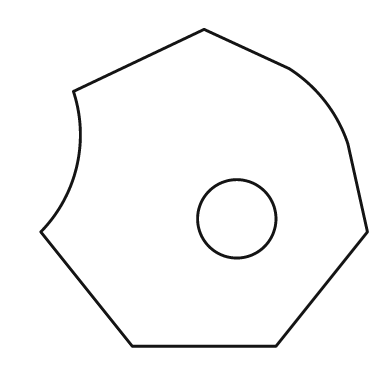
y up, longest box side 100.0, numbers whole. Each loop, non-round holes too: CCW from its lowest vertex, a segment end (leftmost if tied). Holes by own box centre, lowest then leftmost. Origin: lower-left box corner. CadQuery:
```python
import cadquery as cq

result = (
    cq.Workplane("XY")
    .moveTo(28.0, 0.0)
    .lineTo(72.0, 0.0)
    .lineTo(100.0, 35.0)
    .lineTo(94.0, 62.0)
    .threePointArc((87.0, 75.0), (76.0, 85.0))
    .lineTo(50.0, 97.0)
    .lineTo(10.0, 78.0)
    .threePointArc((11.0, 55.0), (0.0, 35.0))
    .close()
    .moveTo(60.0, 39.0)
    .circle(12.0)
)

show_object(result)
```